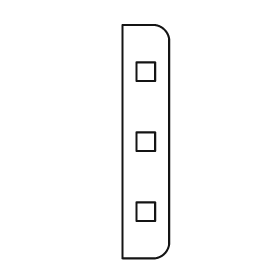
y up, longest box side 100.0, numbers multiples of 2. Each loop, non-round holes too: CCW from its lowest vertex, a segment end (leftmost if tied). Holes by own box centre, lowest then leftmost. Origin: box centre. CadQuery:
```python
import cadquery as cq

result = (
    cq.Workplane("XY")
    .moveTo(-10.0, -50.0)
    .lineTo(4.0, -50.0)
    .threePointArc((8.0, -48.0), (10.0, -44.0))
    .lineTo(10.0, 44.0)
    .threePointArc((8.0, 48.0), (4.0, 50.0))
    .lineTo(-10.0, 50.0)
    .close()
    .moveTo(-4.0, -34.0)
    .lineTo(4.0, -34.0)
    .lineTo(4.0, -26.0)
    .lineTo(-4.0, -26.0)
    .close()
    .moveTo(-4.0, -4.0)
    .lineTo(4.0, -4.0)
    .lineTo(4.0, 4.0)
    .lineTo(-4.0, 4.0)
    .close()
    .moveTo(-4.0, 26.0)
    .lineTo(4.0, 26.0)
    .lineTo(4.0, 34.0)
    .lineTo(-4.0, 34.0)
    .close()
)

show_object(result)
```